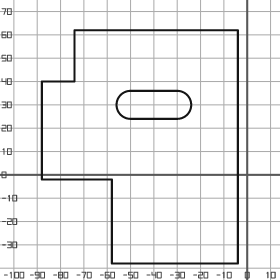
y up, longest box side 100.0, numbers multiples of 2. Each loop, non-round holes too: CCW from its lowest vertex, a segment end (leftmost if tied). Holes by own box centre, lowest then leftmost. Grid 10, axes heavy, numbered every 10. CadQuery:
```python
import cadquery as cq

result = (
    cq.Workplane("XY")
    .moveTo(-58.0, -38.0)
    .lineTo(-4.0, -38.0)
    .lineTo(-4.0, 62.0)
    .lineTo(-74.0, 62.0)
    .lineTo(-74.0, 40.0)
    .lineTo(-88.0, 40.0)
    .lineTo(-88.0, -2.0)
    .lineTo(-58.0, -2.0)
    .close()
    .moveTo(-50.0, 24.0)
    .lineTo(-30.0, 24.0)
    .threePointArc((-24.0, 30.0), (-30.0, 36.0))
    .lineTo(-50.0, 36.0)
    .threePointArc((-56.0, 30.0), (-50.0, 24.0))
    .close()
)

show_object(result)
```